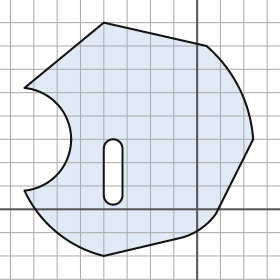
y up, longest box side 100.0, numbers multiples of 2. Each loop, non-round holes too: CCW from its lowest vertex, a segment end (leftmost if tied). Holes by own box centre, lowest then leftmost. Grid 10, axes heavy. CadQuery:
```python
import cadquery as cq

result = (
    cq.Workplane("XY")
    .moveTo(-40.0, -20.0)
    .lineTo(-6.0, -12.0)
    .threePointArc((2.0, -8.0), (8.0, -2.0))
    .lineTo(24.0, 30.0)
    .threePointArc((18.0, 52.0), (4.0, 70.0))
    .lineTo(-40.0, 80.0)
    .lineTo(-74.0, 52.0)
    .threePointArc((-54.0, 30.0), (-74.0, 8.0))
    .threePointArc((-60.0, -10.0), (-40.0, -20.0))
    .close()
    .moveTo(-40.0, 6.0)
    .threePointArc((-36.0, 2.0), (-32.0, 6.0))
    .lineTo(-32.0, 26.0)
    .threePointArc((-36.0, 30.0), (-40.0, 26.0))
    .close()
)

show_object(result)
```